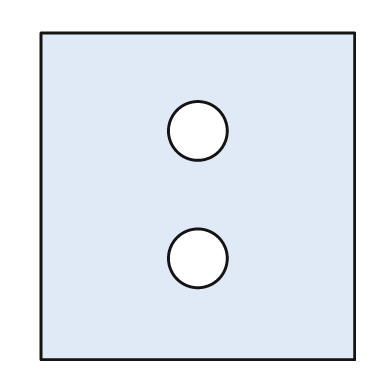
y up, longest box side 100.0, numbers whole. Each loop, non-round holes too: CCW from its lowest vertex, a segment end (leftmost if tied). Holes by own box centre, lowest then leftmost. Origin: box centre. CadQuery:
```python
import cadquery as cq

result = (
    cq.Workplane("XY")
    .moveTo(-48.0, -50.0)
    .lineTo(48.0, -50.0)
    .lineTo(48.0, 50.0)
    .lineTo(-48.0, 50.0)
    .close()
    .moveTo(0.0, -19.0)
    .circle(9.0)
    .moveTo(0.0, 20.0)
    .circle(9.0)
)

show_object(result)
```